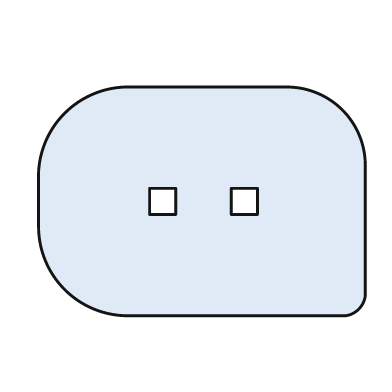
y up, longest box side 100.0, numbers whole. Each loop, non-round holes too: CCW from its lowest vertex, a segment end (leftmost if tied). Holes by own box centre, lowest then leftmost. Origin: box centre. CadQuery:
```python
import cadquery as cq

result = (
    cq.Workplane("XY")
    .moveTo(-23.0, -35.0)
    .lineTo(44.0, -35.0)
    .threePointArc((48.0, -33.0), (50.0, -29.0))
    .lineTo(50.0, 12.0)
    .threePointArc((43.0, 28.0), (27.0, 35.0))
    .lineTo(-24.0, 35.0)
    .threePointArc((-42.0, 27.0), (-50.0, 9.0))
    .lineTo(-50.0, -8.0)
    .threePointArc((-42.0, -27.0), (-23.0, -35.0))
    .close()
    .moveTo(-16.0, -4.0)
    .lineTo(-8.0, -4.0)
    .lineTo(-8.0, 4.0)
    .lineTo(-16.0, 4.0)
    .close()
    .moveTo(9.0, -4.0)
    .lineTo(17.0, -4.0)
    .lineTo(17.0, 4.0)
    .lineTo(9.0, 4.0)
    .close()
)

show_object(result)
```